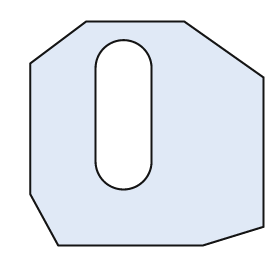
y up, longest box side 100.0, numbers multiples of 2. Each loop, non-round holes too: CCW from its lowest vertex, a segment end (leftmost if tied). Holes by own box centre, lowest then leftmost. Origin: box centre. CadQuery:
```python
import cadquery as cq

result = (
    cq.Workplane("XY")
    .moveTo(-38.0, -48.0)
    .lineTo(24.0, -48.0)
    .lineTo(50.0, -40.0)
    .lineTo(50.0, 24.0)
    .lineTo(16.0, 48.0)
    .lineTo(-26.0, 48.0)
    .lineTo(-50.0, 30.0)
    .lineTo(-50.0, -26.0)
    .close()
    .moveTo(-22.0, -12.0)
    .threePointArc((-10.0, -24.0), (2.0, -12.0))
    .lineTo(2.0, 28.0)
    .threePointArc((-10.0, 40.0), (-22.0, 28.0))
    .close()
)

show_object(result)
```